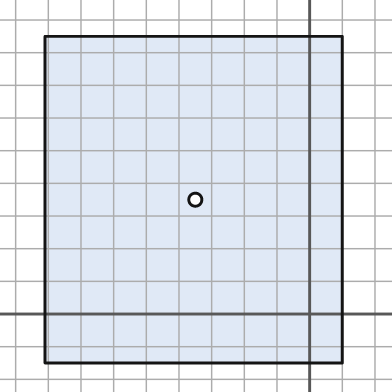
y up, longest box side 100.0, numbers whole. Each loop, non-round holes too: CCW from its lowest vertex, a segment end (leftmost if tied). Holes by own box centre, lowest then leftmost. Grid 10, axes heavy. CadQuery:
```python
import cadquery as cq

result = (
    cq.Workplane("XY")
    .moveTo(-81.0, -15.0)
    .lineTo(10.0, -15.0)
    .lineTo(10.0, 85.0)
    .lineTo(-81.0, 85.0)
    .close()
    .moveTo(-35.0, 35.0)
    .circle(2.0)
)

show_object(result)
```